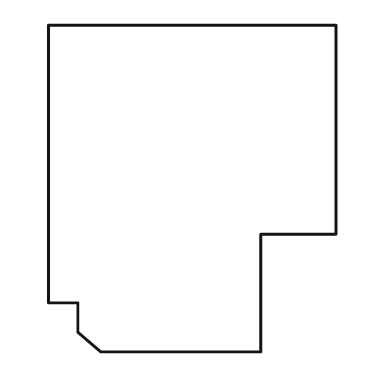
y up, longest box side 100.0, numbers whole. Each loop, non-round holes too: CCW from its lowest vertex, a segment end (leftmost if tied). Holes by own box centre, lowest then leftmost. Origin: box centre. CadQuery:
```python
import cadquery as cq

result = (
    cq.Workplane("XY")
    .moveTo(-28.0, -50.0)
    .lineTo(21.0, -50.0)
    .lineTo(21.0, -14.0)
    .lineTo(44.0, -14.0)
    .lineTo(44.0, 50.0)
    .lineTo(-44.0, 50.0)
    .lineTo(-44.0, -35.0)
    .lineTo(-35.0, -35.0)
    .lineTo(-35.0, -44.0)
    .close()
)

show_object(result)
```